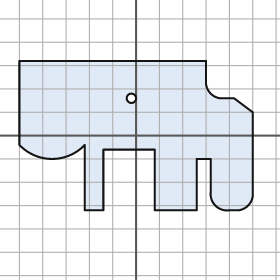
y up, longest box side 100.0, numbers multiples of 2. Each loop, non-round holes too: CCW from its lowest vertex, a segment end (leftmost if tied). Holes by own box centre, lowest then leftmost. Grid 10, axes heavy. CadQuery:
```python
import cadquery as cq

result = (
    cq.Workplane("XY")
    .moveTo(-22.0, -32.0)
    .lineTo(-14.0, -32.0)
    .lineTo(-14.0, -6.0)
    .lineTo(8.0, -6.0)
    .lineTo(8.0, -32.0)
    .lineTo(26.0, -32.0)
    .lineTo(26.0, -10.0)
    .lineTo(32.0, -10.0)
    .lineTo(32.0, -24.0)
    .threePointArc((34.0, -30.0), (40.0, -32.0))
    .lineTo(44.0, -32.0)
    .threePointArc((48.0, -30.0), (50.0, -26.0))
    .lineTo(50.0, 10.0)
    .lineTo(42.0, 16.0)
    .lineTo(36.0, 16.0)
    .threePointArc((32.0, 18.0), (30.0, 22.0))
    .lineTo(30.0, 32.0)
    .lineTo(-50.0, 32.0)
    .lineTo(-50.0, -4.0)
    .threePointArc((-36.0, -10.0), (-22.0, -4.0))
    .close()
    .moveTo(-2.0, 16.0)
    .circle(2.0)
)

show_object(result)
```